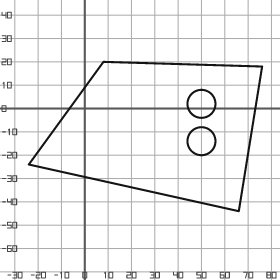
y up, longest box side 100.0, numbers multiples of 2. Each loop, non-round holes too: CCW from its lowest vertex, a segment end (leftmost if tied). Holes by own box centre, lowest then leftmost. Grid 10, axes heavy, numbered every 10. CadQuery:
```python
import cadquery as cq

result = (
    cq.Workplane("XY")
    .moveTo(66.0, -44.0)
    .lineTo(76.0, 18.0)
    .lineTo(8.0, 20.0)
    .lineTo(-24.0, -24.0)
    .close()
    .moveTo(50.0, -14.0)
    .circle(6.0)
    .moveTo(50.0, 2.0)
    .circle(6.0)
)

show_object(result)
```